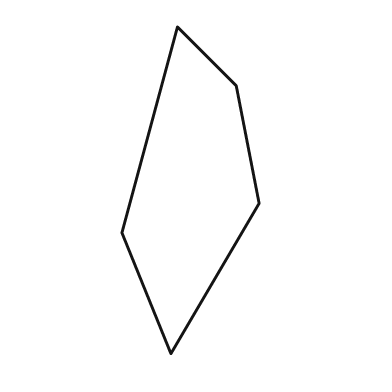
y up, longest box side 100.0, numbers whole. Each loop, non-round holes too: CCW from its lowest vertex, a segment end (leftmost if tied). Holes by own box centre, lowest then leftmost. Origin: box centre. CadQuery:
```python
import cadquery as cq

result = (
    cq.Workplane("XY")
    .moveTo(-6.0, -50.0)
    .lineTo(21.0, -4.0)
    .lineTo(14.0, 32.0)
    .lineTo(-4.0, 50.0)
    .lineTo(-21.0, -13.0)
    .close()
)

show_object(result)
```